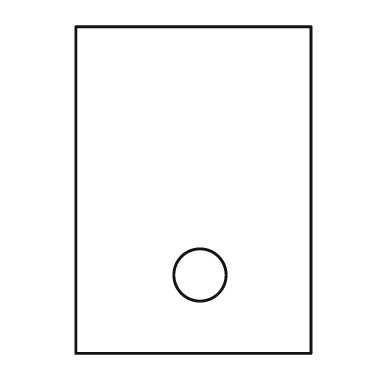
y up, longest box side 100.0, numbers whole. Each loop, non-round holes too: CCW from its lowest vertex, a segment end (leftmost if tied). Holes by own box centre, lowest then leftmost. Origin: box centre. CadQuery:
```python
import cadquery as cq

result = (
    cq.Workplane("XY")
    .moveTo(-36.0, -50.0)
    .lineTo(36.0, -50.0)
    .lineTo(36.0, 50.0)
    .lineTo(-36.0, 50.0)
    .close()
    .moveTo(2.0, -26.0)
    .circle(8.0)
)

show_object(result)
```